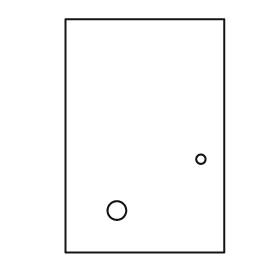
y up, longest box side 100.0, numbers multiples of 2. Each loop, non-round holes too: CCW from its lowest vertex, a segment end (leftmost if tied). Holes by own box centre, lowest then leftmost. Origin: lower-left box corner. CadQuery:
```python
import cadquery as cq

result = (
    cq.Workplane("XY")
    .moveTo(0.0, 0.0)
    .lineTo(68.0, 0.0)
    .lineTo(68.0, 100.0)
    .lineTo(0.0, 100.0)
    .close()
    .moveTo(22.0, 18.0)
    .circle(4.0)
    .moveTo(58.0, 40.0)
    .circle(2.0)
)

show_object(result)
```